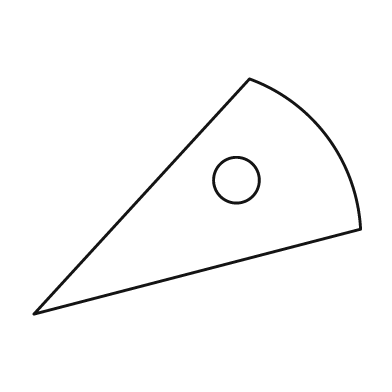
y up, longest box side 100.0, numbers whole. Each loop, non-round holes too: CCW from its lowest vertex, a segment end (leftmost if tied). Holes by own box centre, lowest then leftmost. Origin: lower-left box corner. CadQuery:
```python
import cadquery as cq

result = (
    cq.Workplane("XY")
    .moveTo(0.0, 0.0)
    .lineTo(100.0, 26.0)
    .threePointArc((90.0, 54.0), (66.0, 72.0))
    .close()
    .moveTo(62.0, 41.0)
    .circle(7.0)
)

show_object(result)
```